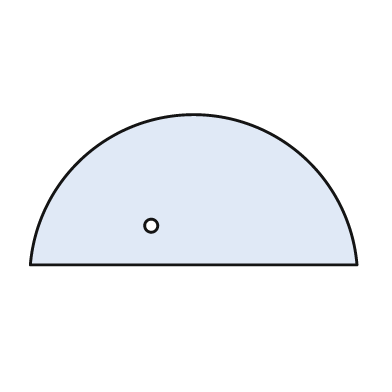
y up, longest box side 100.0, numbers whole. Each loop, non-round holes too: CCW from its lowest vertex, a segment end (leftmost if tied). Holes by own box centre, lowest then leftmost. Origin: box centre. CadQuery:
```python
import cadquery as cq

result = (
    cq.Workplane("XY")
    .moveTo(-50.0, -23.0)
    .lineTo(50.0, -23.0)
    .threePointArc((0.0, 23.0), (-50.0, -23.0))
    .close()
    .moveTo(-13.0, -11.0)
    .circle(2.0)
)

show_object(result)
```